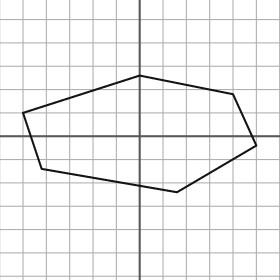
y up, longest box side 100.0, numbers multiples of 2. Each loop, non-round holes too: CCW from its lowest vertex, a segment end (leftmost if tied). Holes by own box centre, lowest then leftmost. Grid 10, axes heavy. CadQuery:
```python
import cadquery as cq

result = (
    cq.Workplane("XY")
    .moveTo(16.0, -24.0)
    .lineTo(50.0, -4.0)
    .lineTo(40.0, 18.0)
    .lineTo(0.0, 26.0)
    .lineTo(-50.0, 10.0)
    .lineTo(-42.0, -14.0)
    .close()
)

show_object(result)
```